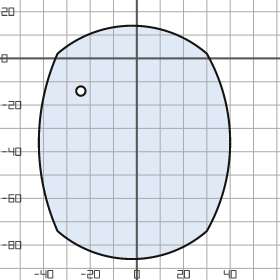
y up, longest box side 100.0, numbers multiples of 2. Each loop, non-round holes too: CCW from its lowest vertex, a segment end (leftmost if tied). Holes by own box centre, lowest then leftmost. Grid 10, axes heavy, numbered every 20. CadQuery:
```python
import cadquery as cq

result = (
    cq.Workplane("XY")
    .moveTo(-34.0, -74.0)
    .threePointArc((-2.0, -86.0), (30.0, -74.0))
    .threePointArc((40.0, -36.0), (30.0, 2.0))
    .threePointArc((-2.0, 14.0), (-34.0, 2.0))
    .threePointArc((-42.0, -36.0), (-34.0, -74.0))
    .close()
    .moveTo(-24.0, -14.0)
    .circle(2.0)
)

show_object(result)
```